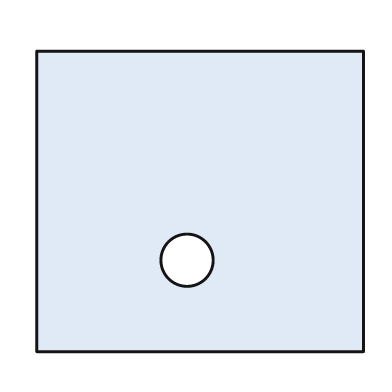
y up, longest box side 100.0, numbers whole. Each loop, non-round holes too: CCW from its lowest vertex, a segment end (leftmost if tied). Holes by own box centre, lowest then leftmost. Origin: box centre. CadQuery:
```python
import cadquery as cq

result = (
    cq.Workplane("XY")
    .moveTo(-50.0, -46.0)
    .lineTo(50.0, -46.0)
    .lineTo(50.0, 46.0)
    .lineTo(-50.0, 46.0)
    .close()
    .moveTo(-4.0, -18.0)
    .circle(8.0)
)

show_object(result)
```